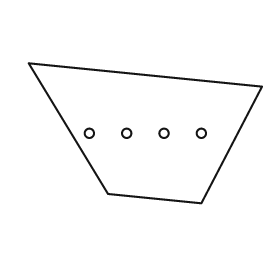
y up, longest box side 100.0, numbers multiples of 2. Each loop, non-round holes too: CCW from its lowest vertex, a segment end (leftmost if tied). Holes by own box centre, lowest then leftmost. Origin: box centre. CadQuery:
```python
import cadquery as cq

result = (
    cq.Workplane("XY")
    .moveTo(24.0, -30.0)
    .lineTo(50.0, 20.0)
    .lineTo(-50.0, 30.0)
    .lineTo(-16.0, -26.0)
    .close()
    .moveTo(-24.0, 0.0)
    .circle(2.0)
    .moveTo(-8.0, 0.0)
    .circle(2.0)
    .moveTo(8.0, 0.0)
    .circle(2.0)
    .moveTo(24.0, 0.0)
    .circle(2.0)
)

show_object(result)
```